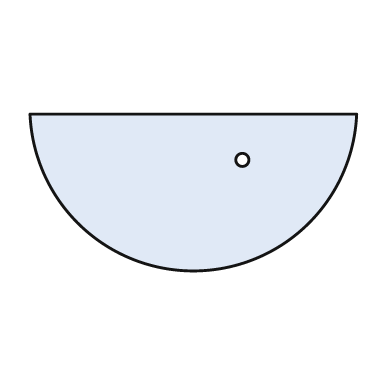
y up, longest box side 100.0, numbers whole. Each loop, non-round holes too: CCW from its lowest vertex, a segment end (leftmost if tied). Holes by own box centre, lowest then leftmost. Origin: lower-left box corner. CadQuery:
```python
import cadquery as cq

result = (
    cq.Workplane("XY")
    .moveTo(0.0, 48.0)
    .threePointArc((50.0, 0.0), (100.0, 48.0))
    .close()
    .moveTo(65.0, 34.0)
    .circle(2.0)
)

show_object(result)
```